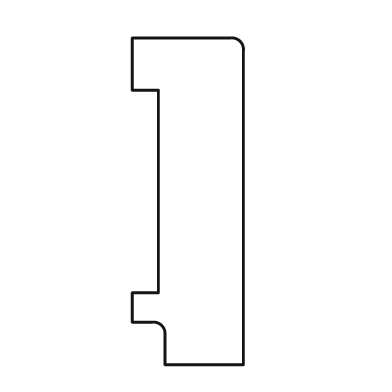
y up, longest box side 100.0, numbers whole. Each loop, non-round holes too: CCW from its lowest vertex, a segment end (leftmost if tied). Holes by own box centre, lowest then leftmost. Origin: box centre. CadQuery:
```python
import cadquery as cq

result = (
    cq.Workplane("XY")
    .moveTo(-7.0, -50.0)
    .lineTo(17.0, -50.0)
    .lineTo(17.0, 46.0)
    .threePointArc((16.0, 49.0), (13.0, 50.0))
    .lineTo(-17.0, 50.0)
    .lineTo(-17.0, 34.0)
    .lineTo(-9.0, 34.0)
    .lineTo(-9.0, -28.0)
    .lineTo(-17.0, -28.0)
    .lineTo(-17.0, -37.0)
    .lineTo(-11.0, -37.0)
    .threePointArc((-8.0, -38.0), (-7.0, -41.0))
    .close()
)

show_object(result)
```